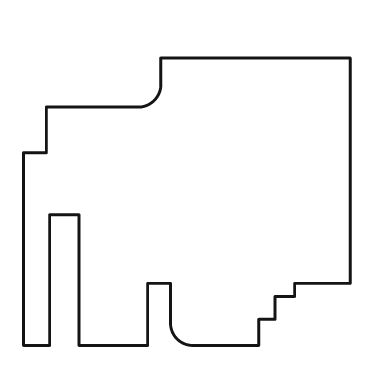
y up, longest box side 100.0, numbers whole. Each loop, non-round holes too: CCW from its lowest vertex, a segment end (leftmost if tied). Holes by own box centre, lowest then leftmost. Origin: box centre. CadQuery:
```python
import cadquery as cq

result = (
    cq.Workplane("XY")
    .moveTo(-50.0, -44.0)
    .lineTo(-42.0, -44.0)
    .lineTo(-42.0, -4.0)
    .lineTo(-33.0, -4.0)
    .lineTo(-33.0, -44.0)
    .lineTo(-12.0, -44.0)
    .lineTo(-12.0, -25.0)
    .lineTo(-5.0, -25.0)
    .lineTo(-5.0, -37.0)
    .threePointArc((-3.0, -42.0), (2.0, -44.0))
    .lineTo(22.0, -44.0)
    .lineTo(22.0, -36.0)
    .lineTo(27.0, -36.0)
    .lineTo(27.0, -29.0)
    .lineTo(33.0, -29.0)
    .lineTo(33.0, -25.0)
    .lineTo(50.0, -25.0)
    .lineTo(50.0, 44.0)
    .lineTo(-8.0, 44.0)
    .lineTo(-8.0, 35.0)
    .threePointArc((-10.0, 31.0), (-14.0, 29.0))
    .lineTo(-43.0, 29.0)
    .lineTo(-43.0, 15.0)
    .lineTo(-50.0, 15.0)
    .close()
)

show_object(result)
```